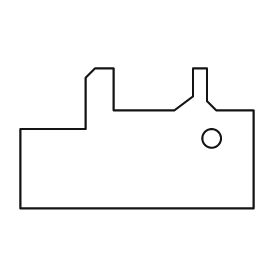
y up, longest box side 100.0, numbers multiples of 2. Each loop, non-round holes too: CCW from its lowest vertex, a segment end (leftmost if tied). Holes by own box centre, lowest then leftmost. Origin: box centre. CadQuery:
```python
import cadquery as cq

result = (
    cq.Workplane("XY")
    .moveTo(-50.0, -30.0)
    .lineTo(50.0, -30.0)
    .lineTo(50.0, 12.0)
    .lineTo(34.0, 12.0)
    .lineTo(30.0, 16.0)
    .lineTo(30.0, 30.0)
    .lineTo(24.0, 30.0)
    .lineTo(24.0, 18.0)
    .lineTo(16.0, 12.0)
    .lineTo(-10.0, 12.0)
    .lineTo(-10.0, 30.0)
    .lineTo(-18.0, 30.0)
    .lineTo(-22.0, 26.0)
    .lineTo(-22.0, 4.0)
    .lineTo(-50.0, 4.0)
    .close()
    .moveTo(32.0, 0.0)
    .circle(4.0)
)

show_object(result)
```